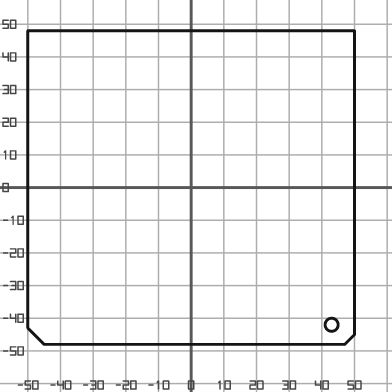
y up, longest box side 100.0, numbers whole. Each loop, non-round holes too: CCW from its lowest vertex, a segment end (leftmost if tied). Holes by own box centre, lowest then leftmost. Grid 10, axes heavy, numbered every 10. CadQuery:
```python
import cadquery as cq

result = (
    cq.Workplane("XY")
    .moveTo(-45.0, -48.0)
    .lineTo(47.0, -48.0)
    .lineTo(50.0, -45.0)
    .lineTo(50.0, 48.0)
    .lineTo(-50.0, 48.0)
    .lineTo(-50.0, -43.0)
    .close()
    .moveTo(43.0, -42.0)
    .circle(2.0)
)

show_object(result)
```